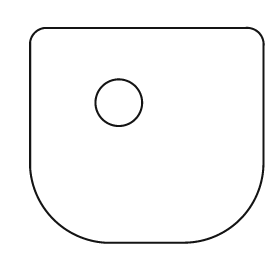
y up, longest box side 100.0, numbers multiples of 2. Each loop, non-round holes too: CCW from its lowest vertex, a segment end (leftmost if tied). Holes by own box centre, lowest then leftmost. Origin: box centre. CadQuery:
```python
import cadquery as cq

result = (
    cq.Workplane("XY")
    .moveTo(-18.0, -46.0)
    .lineTo(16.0, -46.0)
    .threePointArc((40.0, -36.0), (50.0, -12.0))
    .lineTo(50.0, 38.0)
    .threePointArc((48.0, 44.0), (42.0, 46.0))
    .lineTo(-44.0, 46.0)
    .threePointArc((-48.0, 44.0), (-50.0, 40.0))
    .lineTo(-50.0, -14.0)
    .threePointArc((-40.0, -36.0), (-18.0, -46.0))
    .close()
    .moveTo(-12.0, 14.0)
    .circle(10.0)
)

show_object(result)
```